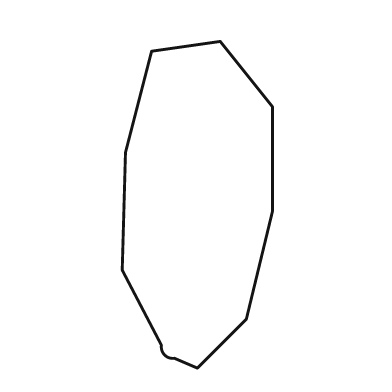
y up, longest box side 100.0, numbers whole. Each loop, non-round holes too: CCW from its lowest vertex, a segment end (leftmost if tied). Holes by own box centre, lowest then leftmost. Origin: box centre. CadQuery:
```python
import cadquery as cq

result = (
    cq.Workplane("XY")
    .moveTo(0.0, -50.0)
    .lineTo(15.0, -35.0)
    .lineTo(23.0, -2.0)
    .lineTo(23.0, 30.0)
    .lineTo(7.0, 50.0)
    .lineTo(-14.0, 47.0)
    .lineTo(-22.0, 16.0)
    .lineTo(-23.0, -20.0)
    .lineTo(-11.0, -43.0)
    .threePointArc((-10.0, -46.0), (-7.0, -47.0))
    .close()
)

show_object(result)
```